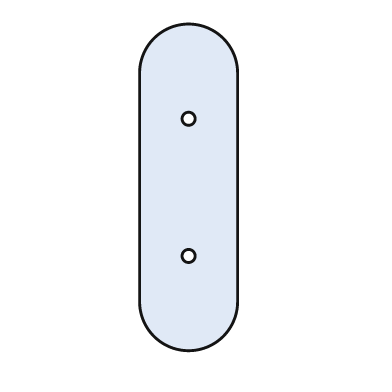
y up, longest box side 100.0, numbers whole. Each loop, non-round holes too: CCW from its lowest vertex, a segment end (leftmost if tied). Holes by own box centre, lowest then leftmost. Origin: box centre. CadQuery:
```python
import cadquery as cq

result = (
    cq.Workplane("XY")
    .moveTo(-15.0, -35.0)
    .threePointArc((0.0, -50.0), (15.0, -35.0))
    .lineTo(15.0, 35.0)
    .threePointArc((0.0, 50.0), (-15.0, 35.0))
    .close()
    .moveTo(0.0, -21.0)
    .circle(2.0)
    .moveTo(0.0, 21.0)
    .circle(2.0)
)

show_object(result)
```